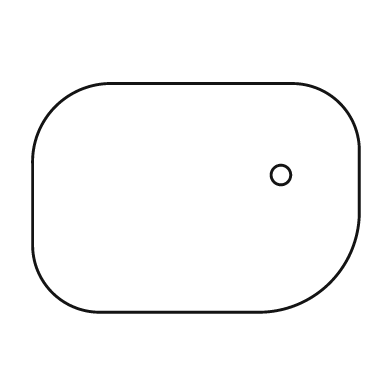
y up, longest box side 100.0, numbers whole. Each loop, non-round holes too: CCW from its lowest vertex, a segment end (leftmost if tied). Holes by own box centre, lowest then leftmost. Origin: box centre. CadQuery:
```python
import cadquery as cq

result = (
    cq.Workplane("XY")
    .moveTo(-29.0, -35.0)
    .lineTo(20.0, -35.0)
    .threePointArc((41.0, -26.0), (50.0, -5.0))
    .lineTo(50.0, 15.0)
    .threePointArc((44.0, 29.0), (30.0, 35.0))
    .lineTo(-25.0, 35.0)
    .threePointArc((-43.0, 28.0), (-50.0, 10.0))
    .lineTo(-50.0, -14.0)
    .threePointArc((-44.0, -29.0), (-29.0, -35.0))
    .close()
    .moveTo(26.0, 7.0)
    .circle(3.0)
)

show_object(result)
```